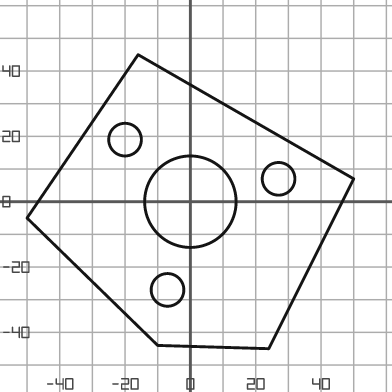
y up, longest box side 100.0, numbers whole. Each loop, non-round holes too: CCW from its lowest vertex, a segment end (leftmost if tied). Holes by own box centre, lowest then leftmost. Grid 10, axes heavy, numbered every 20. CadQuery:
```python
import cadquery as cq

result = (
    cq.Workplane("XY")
    .moveTo(24.0, -45.0)
    .lineTo(50.0, 7.0)
    .lineTo(-16.0, 45.0)
    .lineTo(-50.0, -5.0)
    .lineTo(-10.0, -44.0)
    .close()
    .moveTo(-7.0, -27.0)
    .circle(5.0)
    .moveTo(0.0, 0.0)
    .circle(14.0)
    .moveTo(27.0, 7.0)
    .circle(5.0)
    .moveTo(-20.0, 19.0)
    .circle(5.0)
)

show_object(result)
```